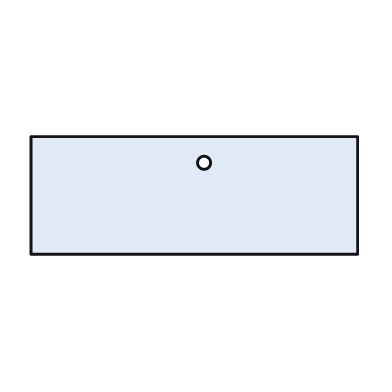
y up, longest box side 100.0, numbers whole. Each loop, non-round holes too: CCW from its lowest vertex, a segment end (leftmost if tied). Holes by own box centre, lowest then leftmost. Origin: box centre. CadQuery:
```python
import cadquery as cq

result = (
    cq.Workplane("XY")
    .moveTo(-50.0, -18.0)
    .lineTo(50.0, -18.0)
    .lineTo(50.0, 18.0)
    .lineTo(-50.0, 18.0)
    .close()
    .moveTo(3.0, 10.0)
    .circle(2.0)
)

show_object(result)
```